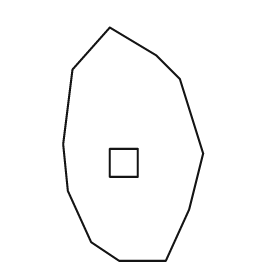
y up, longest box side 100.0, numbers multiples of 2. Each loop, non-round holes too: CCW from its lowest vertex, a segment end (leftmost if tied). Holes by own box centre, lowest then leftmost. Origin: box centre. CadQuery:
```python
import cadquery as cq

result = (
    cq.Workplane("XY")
    .moveTo(-6.0, -50.0)
    .lineTo(14.0, -50.0)
    .lineTo(24.0, -28.0)
    .lineTo(30.0, -4.0)
    .lineTo(20.0, 28.0)
    .lineTo(10.0, 38.0)
    .lineTo(-10.0, 50.0)
    .lineTo(-26.0, 32.0)
    .lineTo(-30.0, 0.0)
    .lineTo(-28.0, -20.0)
    .lineTo(-18.0, -42.0)
    .close()
    .moveTo(-10.0, -14.0)
    .lineTo(2.0, -14.0)
    .lineTo(2.0, -2.0)
    .lineTo(-10.0, -2.0)
    .close()
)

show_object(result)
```